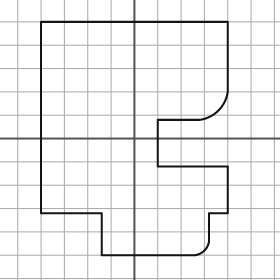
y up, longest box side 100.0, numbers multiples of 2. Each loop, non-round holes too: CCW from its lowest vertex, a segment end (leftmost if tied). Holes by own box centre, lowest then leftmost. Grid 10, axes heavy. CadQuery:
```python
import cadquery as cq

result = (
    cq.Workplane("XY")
    .moveTo(-14.0, -50.0)
    .lineTo(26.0, -50.0)
    .threePointArc((30.0, -48.0), (32.0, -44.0))
    .lineTo(32.0, -32.0)
    .lineTo(40.0, -32.0)
    .lineTo(40.0, -12.0)
    .lineTo(10.0, -12.0)
    .lineTo(10.0, 8.0)
    .lineTo(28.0, 8.0)
    .threePointArc((36.0, 12.0), (40.0, 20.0))
    .lineTo(40.0, 50.0)
    .lineTo(-40.0, 50.0)
    .lineTo(-40.0, -32.0)
    .lineTo(-14.0, -32.0)
    .close()
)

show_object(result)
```